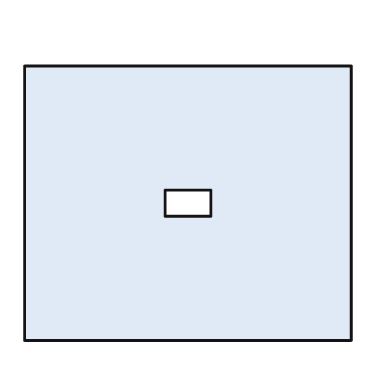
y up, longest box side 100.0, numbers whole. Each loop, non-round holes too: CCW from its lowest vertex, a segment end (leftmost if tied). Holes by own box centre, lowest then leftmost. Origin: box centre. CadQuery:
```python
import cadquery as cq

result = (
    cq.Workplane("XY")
    .moveTo(-50.0, -42.0)
    .lineTo(50.0, -42.0)
    .lineTo(50.0, 42.0)
    .lineTo(-50.0, 42.0)
    .close()
    .moveTo(-7.0, -4.0)
    .lineTo(7.0, -4.0)
    .lineTo(7.0, 4.0)
    .lineTo(-7.0, 4.0)
    .close()
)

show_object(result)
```